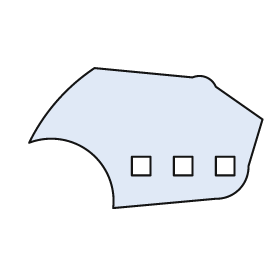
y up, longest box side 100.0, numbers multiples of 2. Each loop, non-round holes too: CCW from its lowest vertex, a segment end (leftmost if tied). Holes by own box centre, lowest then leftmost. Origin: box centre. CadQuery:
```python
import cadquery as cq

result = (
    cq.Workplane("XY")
    .moveTo(-14.0, -30.0)
    .lineTo(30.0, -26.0)
    .threePointArc((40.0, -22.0), (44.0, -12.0))
    .lineTo(50.0, 8.0)
    .lineTo(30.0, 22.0)
    .threePointArc((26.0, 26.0), (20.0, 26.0))
    .lineTo(-22.0, 30.0)
    .threePointArc((-38.0, 16.0), (-50.0, -2.0))
    .threePointArc((-24.0, -6.0), (-14.0, -30.0))
    .close()
    .moveTo(-6.0, -16.0)
    .lineTo(2.0, -16.0)
    .lineTo(2.0, -8.0)
    .lineTo(-6.0, -8.0)
    .close()
    .moveTo(12.0, -16.0)
    .lineTo(20.0, -16.0)
    .lineTo(20.0, -8.0)
    .lineTo(12.0, -8.0)
    .close()
    .moveTo(30.0, -16.0)
    .lineTo(38.0, -16.0)
    .lineTo(38.0, -8.0)
    .lineTo(30.0, -8.0)
    .close()
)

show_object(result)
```